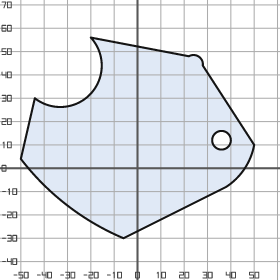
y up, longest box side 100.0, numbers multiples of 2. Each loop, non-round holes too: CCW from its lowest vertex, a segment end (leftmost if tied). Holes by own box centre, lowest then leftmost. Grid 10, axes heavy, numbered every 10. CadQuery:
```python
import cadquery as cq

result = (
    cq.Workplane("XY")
    .moveTo(-6.0, -30.0)
    .lineTo(38.0, -8.0)
    .threePointArc((46.0, 0.0), (50.0, 10.0))
    .lineTo(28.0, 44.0)
    .threePointArc((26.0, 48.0), (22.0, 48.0))
    .lineTo(-20.0, 56.0)
    .threePointArc((-20.0, 32.0), (-44.0, 30.0))
    .lineTo(-50.0, 4.0)
    .threePointArc((-30.0, -16.0), (-6.0, -30.0))
    .close()
    .moveTo(36.0, 12.0)
    .circle(4.0)
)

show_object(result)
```